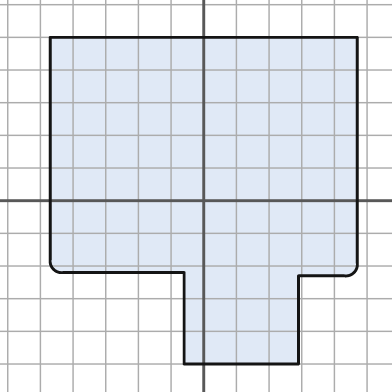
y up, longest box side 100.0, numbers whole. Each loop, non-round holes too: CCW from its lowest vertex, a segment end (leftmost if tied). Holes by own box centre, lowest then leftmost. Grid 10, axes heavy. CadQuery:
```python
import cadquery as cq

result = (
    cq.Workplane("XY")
    .moveTo(-6.0, -50.0)
    .lineTo(29.0, -50.0)
    .lineTo(29.0, -23.0)
    .lineTo(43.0, -23.0)
    .threePointArc((46.0, -22.0), (47.0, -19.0))
    .lineTo(47.0, 50.0)
    .lineTo(-47.0, 50.0)
    .lineTo(-47.0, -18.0)
    .threePointArc((-46.0, -21.0), (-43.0, -22.0))
    .lineTo(-6.0, -22.0)
    .close()
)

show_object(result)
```